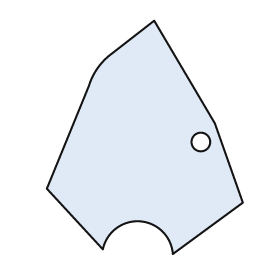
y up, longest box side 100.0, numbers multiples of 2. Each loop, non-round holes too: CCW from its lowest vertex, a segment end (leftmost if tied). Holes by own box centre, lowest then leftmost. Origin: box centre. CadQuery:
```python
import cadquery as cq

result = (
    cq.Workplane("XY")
    .moveTo(12.0, -50.0)
    .lineTo(42.0, -28.0)
    .lineTo(30.0, 6.0)
    .lineTo(4.0, 50.0)
    .lineTo(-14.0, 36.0)
    .threePointArc((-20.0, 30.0), (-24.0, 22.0))
    .lineTo(-42.0, -22.0)
    .lineTo(-18.0, -48.0)
    .threePointArc((-2.0, -36.0), (12.0, -50.0))
    .close()
    .moveTo(24.0, -2.0)
    .circle(4.0)
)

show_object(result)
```